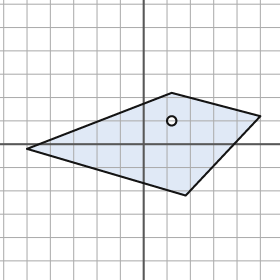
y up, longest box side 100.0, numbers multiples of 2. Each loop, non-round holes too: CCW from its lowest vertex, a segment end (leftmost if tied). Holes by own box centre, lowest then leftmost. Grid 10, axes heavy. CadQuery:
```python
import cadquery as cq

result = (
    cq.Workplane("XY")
    .moveTo(18.0, -22.0)
    .lineTo(50.0, 12.0)
    .lineTo(12.0, 22.0)
    .lineTo(-50.0, -2.0)
    .close()
    .moveTo(12.0, 10.0)
    .circle(2.0)
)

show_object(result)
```